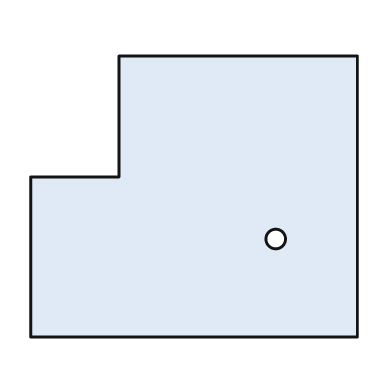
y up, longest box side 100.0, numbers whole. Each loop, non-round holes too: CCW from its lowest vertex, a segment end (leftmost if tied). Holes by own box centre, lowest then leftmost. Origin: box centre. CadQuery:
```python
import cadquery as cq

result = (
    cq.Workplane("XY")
    .moveTo(-50.0, -43.0)
    .lineTo(50.0, -43.0)
    .lineTo(50.0, 43.0)
    .lineTo(-23.0, 43.0)
    .lineTo(-23.0, 6.0)
    .lineTo(-50.0, 6.0)
    .close()
    .moveTo(25.0, -13.0)
    .circle(3.0)
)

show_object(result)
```